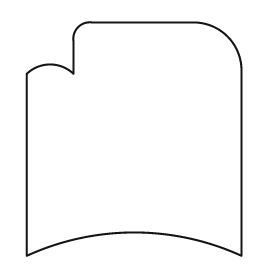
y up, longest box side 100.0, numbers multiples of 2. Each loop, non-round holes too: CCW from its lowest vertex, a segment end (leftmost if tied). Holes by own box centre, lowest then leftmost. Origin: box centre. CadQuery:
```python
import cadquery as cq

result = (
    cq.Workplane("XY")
    .moveTo(-46.0, -50.0)
    .threePointArc((0.0, -40.0), (46.0, -50.0))
    .lineTo(46.0, 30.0)
    .threePointArc((40.0, 44.0), (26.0, 50.0))
    .lineTo(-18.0, 50.0)
    .threePointArc((-24.0, 48.0), (-26.0, 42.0))
    .lineTo(-26.0, 28.0)
    .threePointArc((-36.0, 32.0), (-46.0, 28.0))
    .close()
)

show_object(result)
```